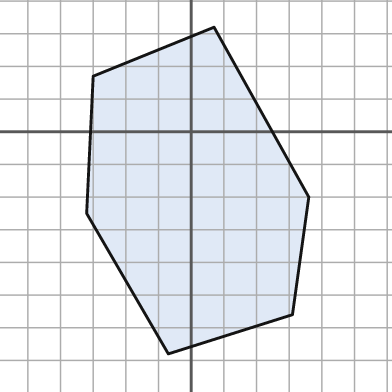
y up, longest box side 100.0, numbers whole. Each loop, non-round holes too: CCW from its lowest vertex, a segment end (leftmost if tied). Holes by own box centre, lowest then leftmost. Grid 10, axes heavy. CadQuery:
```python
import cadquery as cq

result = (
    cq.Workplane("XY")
    .moveTo(-7.0, -68.0)
    .lineTo(31.0, -56.0)
    .lineTo(36.0, -20.0)
    .lineTo(7.0, 32.0)
    .lineTo(-30.0, 17.0)
    .lineTo(-32.0, -25.0)
    .close()
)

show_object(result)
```